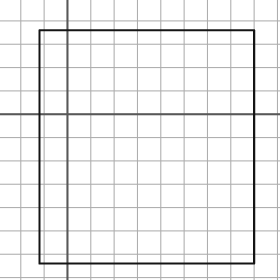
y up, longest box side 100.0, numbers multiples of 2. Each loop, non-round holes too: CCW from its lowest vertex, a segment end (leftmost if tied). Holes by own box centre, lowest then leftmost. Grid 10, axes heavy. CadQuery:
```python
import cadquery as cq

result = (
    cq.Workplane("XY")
    .moveTo(-12.0, -64.0)
    .lineTo(80.0, -64.0)
    .lineTo(80.0, 36.0)
    .lineTo(-12.0, 36.0)
    .close()
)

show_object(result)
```